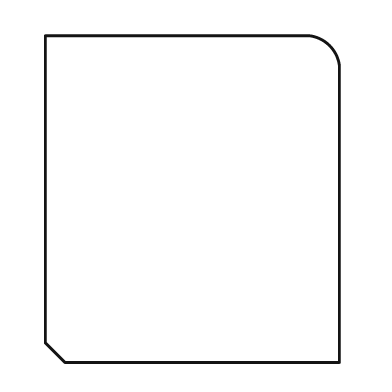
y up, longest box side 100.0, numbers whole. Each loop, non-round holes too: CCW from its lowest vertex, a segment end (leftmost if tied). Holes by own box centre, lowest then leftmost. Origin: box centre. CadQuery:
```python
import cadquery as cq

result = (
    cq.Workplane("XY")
    .moveTo(-39.0, -50.0)
    .lineTo(45.0, -50.0)
    .lineTo(45.0, 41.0)
    .threePointArc((42.0, 47.0), (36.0, 50.0))
    .lineTo(-45.0, 50.0)
    .lineTo(-45.0, -44.0)
    .close()
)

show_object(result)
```